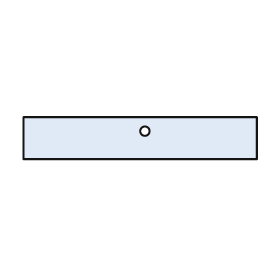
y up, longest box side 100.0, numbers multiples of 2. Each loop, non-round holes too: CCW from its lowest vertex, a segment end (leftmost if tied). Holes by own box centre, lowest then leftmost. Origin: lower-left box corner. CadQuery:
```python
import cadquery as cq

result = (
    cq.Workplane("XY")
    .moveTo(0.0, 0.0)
    .lineTo(100.0, 0.0)
    .lineTo(100.0, 18.0)
    .lineTo(0.0, 18.0)
    .close()
    .moveTo(52.0, 12.0)
    .circle(2.0)
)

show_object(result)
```